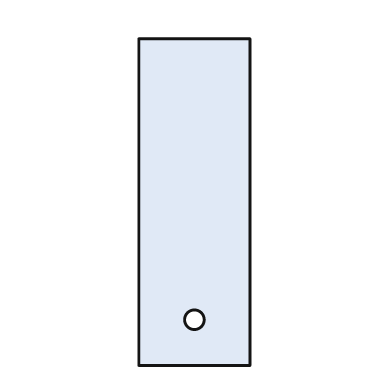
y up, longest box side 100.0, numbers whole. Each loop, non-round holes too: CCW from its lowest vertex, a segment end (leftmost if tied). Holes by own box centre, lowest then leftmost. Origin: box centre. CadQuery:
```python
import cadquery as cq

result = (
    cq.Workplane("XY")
    .moveTo(-17.0, -50.0)
    .lineTo(17.0, -50.0)
    .lineTo(17.0, 50.0)
    .lineTo(-17.0, 50.0)
    .close()
    .moveTo(0.0, -36.0)
    .circle(3.0)
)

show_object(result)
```